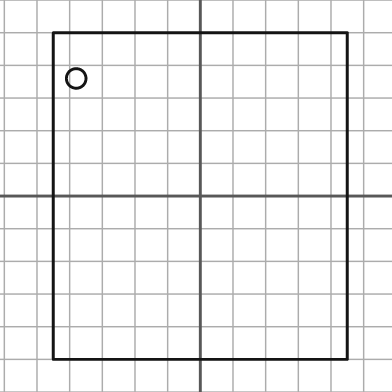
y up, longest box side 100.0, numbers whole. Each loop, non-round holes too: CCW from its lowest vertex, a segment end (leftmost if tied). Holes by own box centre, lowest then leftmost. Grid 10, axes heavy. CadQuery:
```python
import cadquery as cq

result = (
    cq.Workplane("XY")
    .moveTo(-45.0, -50.0)
    .lineTo(45.0, -50.0)
    .lineTo(45.0, 50.0)
    .lineTo(-45.0, 50.0)
    .close()
    .moveTo(-38.0, 36.0)
    .circle(3.0)
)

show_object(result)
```